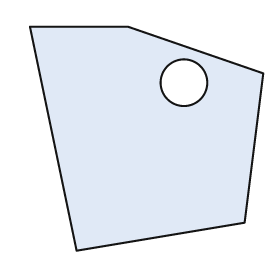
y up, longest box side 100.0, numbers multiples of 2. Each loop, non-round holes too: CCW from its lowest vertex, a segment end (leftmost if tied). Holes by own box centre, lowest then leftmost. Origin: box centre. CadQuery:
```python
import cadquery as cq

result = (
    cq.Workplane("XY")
    .moveTo(-30.0, -48.0)
    .lineTo(42.0, -36.0)
    .lineTo(50.0, 28.0)
    .lineTo(-8.0, 48.0)
    .lineTo(-50.0, 48.0)
    .close()
    .moveTo(16.0, 24.0)
    .circle(10.0)
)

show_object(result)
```